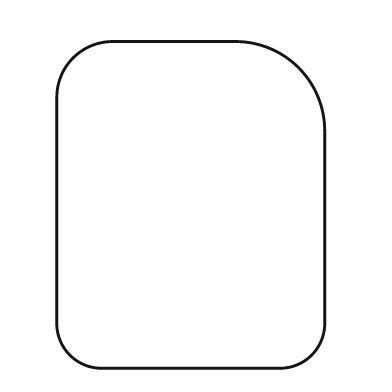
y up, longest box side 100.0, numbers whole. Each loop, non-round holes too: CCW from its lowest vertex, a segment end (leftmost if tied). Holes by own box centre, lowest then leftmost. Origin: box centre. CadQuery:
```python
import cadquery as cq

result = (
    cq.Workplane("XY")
    .moveTo(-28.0, -50.0)
    .lineTo(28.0, -50.0)
    .threePointArc((37.0, -46.0), (41.0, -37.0))
    .lineTo(41.0, 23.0)
    .threePointArc((33.0, 42.0), (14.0, 50.0))
    .lineTo(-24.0, 50.0)
    .threePointArc((-36.0, 45.0), (-41.0, 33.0))
    .lineTo(-41.0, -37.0)
    .threePointArc((-37.0, -46.0), (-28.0, -50.0))
    .close()
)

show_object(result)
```